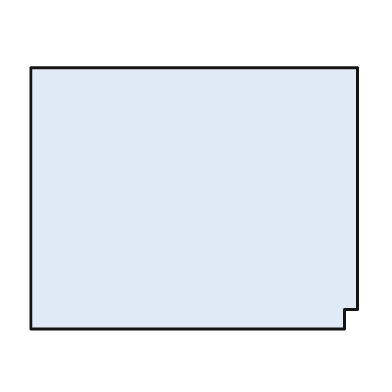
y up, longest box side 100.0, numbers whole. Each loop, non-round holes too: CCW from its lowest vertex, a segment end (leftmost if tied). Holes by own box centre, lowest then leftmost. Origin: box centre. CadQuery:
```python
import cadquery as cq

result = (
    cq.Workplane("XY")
    .moveTo(-50.0, -40.0)
    .lineTo(46.0, -40.0)
    .lineTo(46.0, -34.0)
    .lineTo(50.0, -34.0)
    .lineTo(50.0, 40.0)
    .lineTo(-50.0, 40.0)
    .close()
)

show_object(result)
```